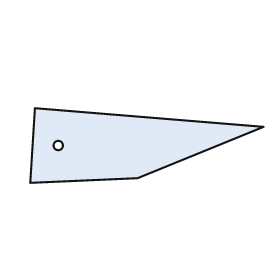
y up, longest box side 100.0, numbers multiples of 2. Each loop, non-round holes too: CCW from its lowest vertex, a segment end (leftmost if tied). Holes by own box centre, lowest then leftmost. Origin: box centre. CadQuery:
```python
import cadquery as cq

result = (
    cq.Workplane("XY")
    .moveTo(-50.0, -16.0)
    .lineTo(-4.0, -14.0)
    .lineTo(50.0, 8.0)
    .lineTo(-48.0, 16.0)
    .close()
    .moveTo(-38.0, 0.0)
    .circle(2.0)
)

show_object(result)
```